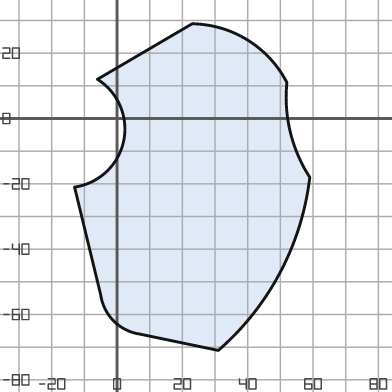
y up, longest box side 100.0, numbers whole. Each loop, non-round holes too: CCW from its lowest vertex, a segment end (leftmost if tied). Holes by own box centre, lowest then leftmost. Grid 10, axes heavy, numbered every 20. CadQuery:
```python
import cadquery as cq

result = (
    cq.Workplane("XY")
    .moveTo(31.0, -71.0)
    .threePointArc((50.0, -47.0), (59.0, -18.0))
    .threePointArc((53.0, -4.0), (52.0, 11.0))
    .threePointArc((40.0, 24.0), (23.0, 29.0))
    .lineTo(-6.0, 12.0)
    .threePointArc((2.0, -7.0), (-13.0, -21.0))
    .lineTo(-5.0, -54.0)
    .threePointArc((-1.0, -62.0), (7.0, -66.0))
    .close()
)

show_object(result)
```